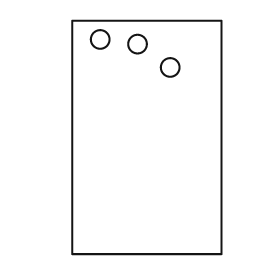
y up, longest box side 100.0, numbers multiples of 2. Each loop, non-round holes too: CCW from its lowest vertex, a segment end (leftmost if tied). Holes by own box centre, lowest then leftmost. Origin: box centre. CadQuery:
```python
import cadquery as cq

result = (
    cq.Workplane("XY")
    .moveTo(-32.0, -50.0)
    .lineTo(32.0, -50.0)
    .lineTo(32.0, 50.0)
    .lineTo(-32.0, 50.0)
    .close()
    .moveTo(10.0, 30.0)
    .circle(4.0)
    .moveTo(-4.0, 40.0)
    .circle(4.0)
    .moveTo(-20.0, 42.0)
    .circle(4.0)
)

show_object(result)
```